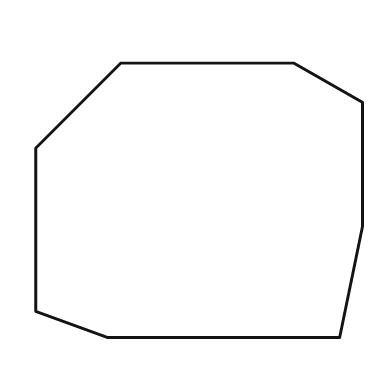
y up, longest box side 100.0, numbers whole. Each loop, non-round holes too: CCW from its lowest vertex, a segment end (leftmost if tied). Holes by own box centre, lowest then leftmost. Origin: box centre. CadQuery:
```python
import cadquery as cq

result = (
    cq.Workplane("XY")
    .moveTo(-28.0, -42.0)
    .lineTo(43.0, -42.0)
    .lineTo(50.0, -8.0)
    .lineTo(50.0, 30.0)
    .lineTo(29.0, 42.0)
    .lineTo(-24.0, 42.0)
    .lineTo(-50.0, 16.0)
    .lineTo(-50.0, -34.0)
    .close()
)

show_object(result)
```